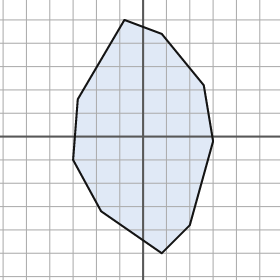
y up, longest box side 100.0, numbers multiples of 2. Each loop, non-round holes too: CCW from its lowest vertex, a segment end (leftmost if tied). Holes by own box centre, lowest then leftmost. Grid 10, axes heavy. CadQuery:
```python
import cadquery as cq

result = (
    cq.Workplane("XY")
    .moveTo(8.0, -50.0)
    .lineTo(20.0, -38.0)
    .lineTo(30.0, -2.0)
    .lineTo(26.0, 22.0)
    .lineTo(8.0, 44.0)
    .lineTo(-8.0, 50.0)
    .lineTo(-28.0, 16.0)
    .lineTo(-30.0, -10.0)
    .lineTo(-18.0, -32.0)
    .close()
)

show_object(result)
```